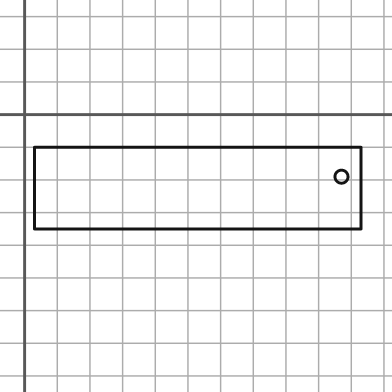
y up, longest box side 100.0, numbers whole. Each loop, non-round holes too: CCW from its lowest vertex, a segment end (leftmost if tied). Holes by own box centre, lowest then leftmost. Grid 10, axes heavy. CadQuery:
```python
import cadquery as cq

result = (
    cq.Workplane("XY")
    .moveTo(3.0, -35.0)
    .lineTo(103.0, -35.0)
    .lineTo(103.0, -10.0)
    .lineTo(3.0, -10.0)
    .close()
    .moveTo(97.0, -19.0)
    .circle(2.0)
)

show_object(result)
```